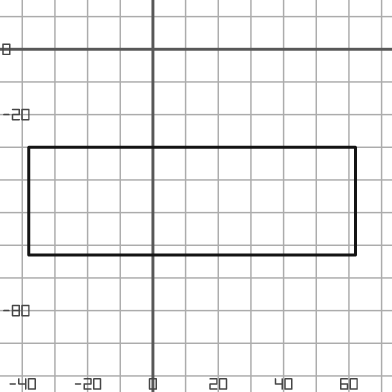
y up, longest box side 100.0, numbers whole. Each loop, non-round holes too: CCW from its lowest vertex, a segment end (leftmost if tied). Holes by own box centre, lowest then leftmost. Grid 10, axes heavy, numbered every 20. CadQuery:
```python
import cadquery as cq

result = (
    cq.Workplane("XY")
    .moveTo(-38.0, -63.0)
    .lineTo(62.0, -63.0)
    .lineTo(62.0, -30.0)
    .lineTo(-38.0, -30.0)
    .close()
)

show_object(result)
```